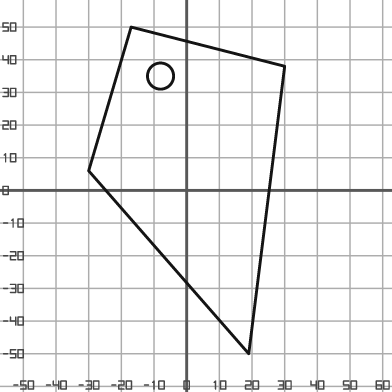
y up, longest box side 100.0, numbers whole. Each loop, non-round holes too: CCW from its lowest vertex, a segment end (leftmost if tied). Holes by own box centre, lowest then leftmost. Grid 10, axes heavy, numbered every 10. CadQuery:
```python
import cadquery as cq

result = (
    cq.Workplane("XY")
    .moveTo(19.0, -50.0)
    .lineTo(30.0, 38.0)
    .lineTo(-17.0, 50.0)
    .lineTo(-30.0, 6.0)
    .close()
    .moveTo(-8.0, 35.0)
    .circle(4.0)
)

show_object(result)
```